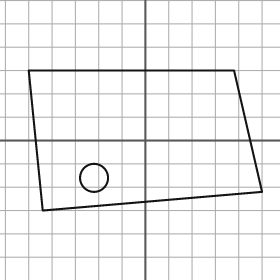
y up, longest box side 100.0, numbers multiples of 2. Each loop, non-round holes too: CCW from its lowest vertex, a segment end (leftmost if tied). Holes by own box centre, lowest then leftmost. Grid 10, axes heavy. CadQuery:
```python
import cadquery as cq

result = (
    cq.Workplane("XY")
    .moveTo(-44.0, -30.0)
    .lineTo(50.0, -22.0)
    .lineTo(38.0, 30.0)
    .lineTo(-50.0, 30.0)
    .close()
    .moveTo(-22.0, -16.0)
    .circle(6.0)
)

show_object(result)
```